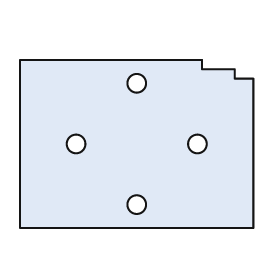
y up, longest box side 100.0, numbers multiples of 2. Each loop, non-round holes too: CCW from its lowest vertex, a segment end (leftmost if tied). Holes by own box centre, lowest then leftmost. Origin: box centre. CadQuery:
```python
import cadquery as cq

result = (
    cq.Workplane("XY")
    .moveTo(-50.0, -36.0)
    .lineTo(50.0, -36.0)
    .lineTo(50.0, 28.0)
    .lineTo(42.0, 28.0)
    .lineTo(42.0, 32.0)
    .lineTo(28.0, 32.0)
    .lineTo(28.0, 36.0)
    .lineTo(-50.0, 36.0)
    .close()
    .moveTo(0.0, -26.0)
    .circle(4.0)
    .moveTo(-26.0, 0.0)
    .circle(4.0)
    .moveTo(26.0, 0.0)
    .circle(4.0)
    .moveTo(0.0, 26.0)
    .circle(4.0)
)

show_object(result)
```